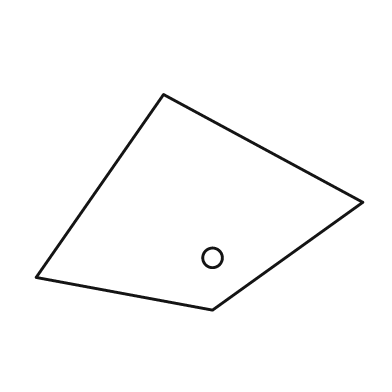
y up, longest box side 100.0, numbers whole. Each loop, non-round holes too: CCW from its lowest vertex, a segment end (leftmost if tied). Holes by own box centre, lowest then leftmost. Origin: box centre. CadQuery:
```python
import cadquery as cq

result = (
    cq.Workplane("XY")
    .moveTo(4.0, -33.0)
    .lineTo(50.0, 0.0)
    .lineTo(-11.0, 33.0)
    .lineTo(-50.0, -23.0)
    .close()
    .moveTo(4.0, -17.0)
    .circle(3.0)
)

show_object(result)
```